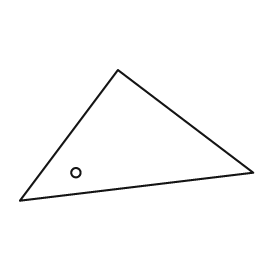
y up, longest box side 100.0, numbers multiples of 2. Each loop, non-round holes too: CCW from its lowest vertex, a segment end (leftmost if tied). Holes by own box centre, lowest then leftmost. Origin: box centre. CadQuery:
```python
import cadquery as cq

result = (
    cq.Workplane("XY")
    .moveTo(-50.0, -28.0)
    .lineTo(50.0, -16.0)
    .lineTo(-8.0, 28.0)
    .close()
    .moveTo(-26.0, -16.0)
    .circle(2.0)
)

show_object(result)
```